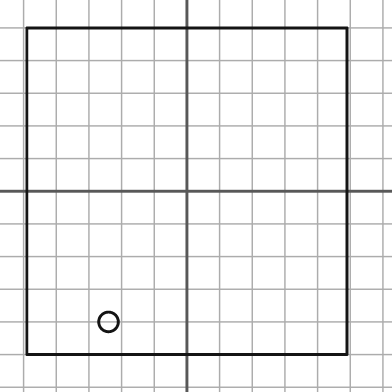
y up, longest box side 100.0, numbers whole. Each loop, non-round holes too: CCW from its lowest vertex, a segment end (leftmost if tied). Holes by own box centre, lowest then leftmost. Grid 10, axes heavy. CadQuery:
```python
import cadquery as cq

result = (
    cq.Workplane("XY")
    .moveTo(-49.0, -50.0)
    .lineTo(49.0, -50.0)
    .lineTo(49.0, 50.0)
    .lineTo(-49.0, 50.0)
    .close()
    .moveTo(-24.0, -40.0)
    .circle(3.0)
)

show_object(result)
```